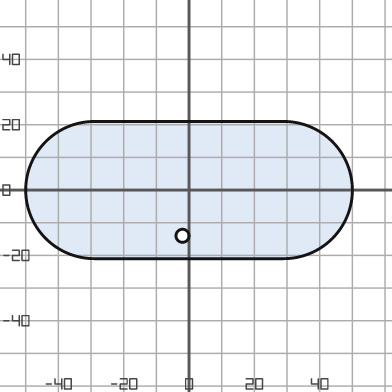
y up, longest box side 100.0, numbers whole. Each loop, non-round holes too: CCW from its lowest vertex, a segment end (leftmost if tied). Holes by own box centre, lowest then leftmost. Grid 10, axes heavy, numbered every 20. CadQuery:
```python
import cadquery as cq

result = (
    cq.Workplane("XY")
    .moveTo(-29.0, -21.0)
    .lineTo(29.0, -21.0)
    .threePointArc((50.0, 0.0), (29.0, 21.0))
    .lineTo(-29.0, 21.0)
    .threePointArc((-50.0, 0.0), (-29.0, -21.0))
    .close()
    .moveTo(-2.0, -14.0)
    .circle(2.0)
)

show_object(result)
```